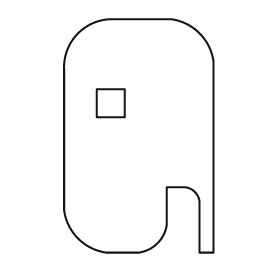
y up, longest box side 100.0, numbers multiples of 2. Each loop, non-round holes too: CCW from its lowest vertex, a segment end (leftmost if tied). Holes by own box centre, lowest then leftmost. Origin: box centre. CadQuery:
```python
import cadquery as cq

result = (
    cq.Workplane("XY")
    .moveTo(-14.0, -50.0)
    .lineTo(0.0, -50.0)
    .threePointArc((8.0, -46.0), (12.0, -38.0))
    .lineTo(12.0, -22.0)
    .lineTo(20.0, -22.0)
    .threePointArc((24.0, -24.0), (26.0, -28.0))
    .lineTo(26.0, -50.0)
    .lineTo(32.0, -50.0)
    .lineTo(32.0, 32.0)
    .threePointArc((26.0, 44.0), (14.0, 50.0))
    .lineTo(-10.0, 50.0)
    .threePointArc((-26.0, 44.0), (-32.0, 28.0))
    .lineTo(-32.0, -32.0)
    .threePointArc((-26.0, -44.0), (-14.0, -50.0))
    .close()
    .moveTo(-18.0, 8.0)
    .lineTo(-6.0, 8.0)
    .lineTo(-6.0, 20.0)
    .lineTo(-18.0, 20.0)
    .close()
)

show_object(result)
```